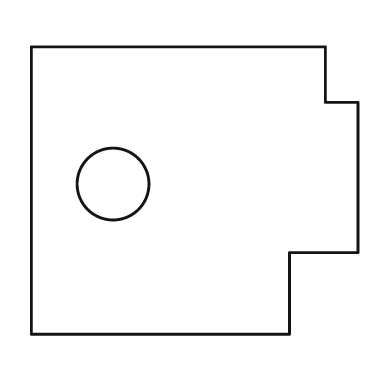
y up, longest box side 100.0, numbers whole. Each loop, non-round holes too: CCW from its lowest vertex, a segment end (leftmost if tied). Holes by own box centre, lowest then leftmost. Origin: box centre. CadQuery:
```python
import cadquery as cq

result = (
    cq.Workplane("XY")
    .moveTo(-50.0, -44.0)
    .lineTo(29.0, -44.0)
    .lineTo(29.0, -19.0)
    .lineTo(50.0, -19.0)
    .lineTo(50.0, 27.0)
    .lineTo(40.0, 27.0)
    .lineTo(40.0, 44.0)
    .lineTo(-50.0, 44.0)
    .close()
    .moveTo(-25.0, 2.0)
    .circle(11.0)
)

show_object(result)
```